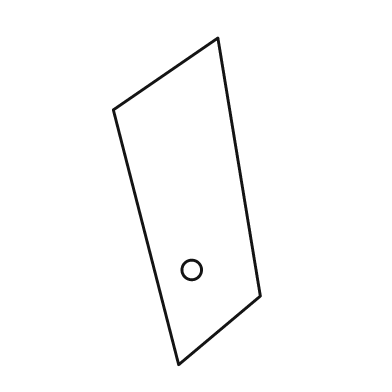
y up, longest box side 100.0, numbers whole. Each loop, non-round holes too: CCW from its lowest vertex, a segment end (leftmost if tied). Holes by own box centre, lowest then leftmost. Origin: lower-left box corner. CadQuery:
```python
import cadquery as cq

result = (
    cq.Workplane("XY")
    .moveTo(20.0, 0.0)
    .lineTo(45.0, 21.0)
    .lineTo(32.0, 100.0)
    .lineTo(0.0, 78.0)
    .close()
    .moveTo(24.0, 29.0)
    .circle(3.0)
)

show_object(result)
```